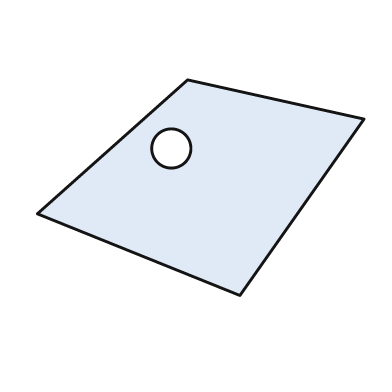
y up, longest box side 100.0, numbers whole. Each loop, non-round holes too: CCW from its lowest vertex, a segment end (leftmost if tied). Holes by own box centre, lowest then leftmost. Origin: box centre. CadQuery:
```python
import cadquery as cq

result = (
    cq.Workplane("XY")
    .moveTo(12.0, -33.0)
    .lineTo(50.0, 21.0)
    .lineTo(-4.0, 33.0)
    .lineTo(-50.0, -8.0)
    .close()
    .moveTo(-9.0, 12.0)
    .circle(6.0)
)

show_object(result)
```